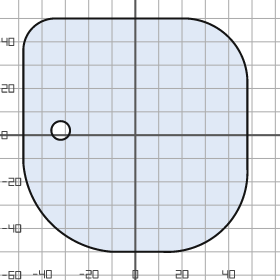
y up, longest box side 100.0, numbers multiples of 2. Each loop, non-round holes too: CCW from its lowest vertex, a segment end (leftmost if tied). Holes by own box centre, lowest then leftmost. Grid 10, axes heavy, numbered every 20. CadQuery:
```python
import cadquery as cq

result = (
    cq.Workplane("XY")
    .moveTo(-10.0, -50.0)
    .lineTo(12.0, -50.0)
    .threePointArc((38.0, -40.0), (48.0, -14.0))
    .lineTo(48.0, 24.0)
    .threePointArc((40.0, 42.0), (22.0, 50.0))
    .lineTo(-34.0, 50.0)
    .threePointArc((-44.0, 46.0), (-48.0, 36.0))
    .lineTo(-48.0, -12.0)
    .threePointArc((-36.0, -38.0), (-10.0, -50.0))
    .close()
    .moveTo(-32.0, 2.0)
    .circle(4.0)
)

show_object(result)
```